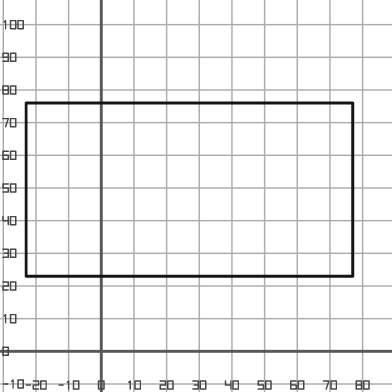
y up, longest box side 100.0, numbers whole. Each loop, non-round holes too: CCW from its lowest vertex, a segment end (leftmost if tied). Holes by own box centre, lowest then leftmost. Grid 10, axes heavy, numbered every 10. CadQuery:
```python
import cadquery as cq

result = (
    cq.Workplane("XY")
    .moveTo(-23.0, 23.0)
    .lineTo(77.0, 23.0)
    .lineTo(77.0, 76.0)
    .lineTo(-23.0, 76.0)
    .close()
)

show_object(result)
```